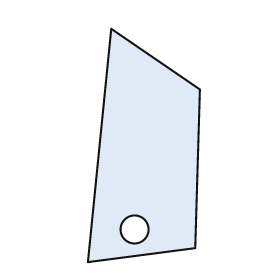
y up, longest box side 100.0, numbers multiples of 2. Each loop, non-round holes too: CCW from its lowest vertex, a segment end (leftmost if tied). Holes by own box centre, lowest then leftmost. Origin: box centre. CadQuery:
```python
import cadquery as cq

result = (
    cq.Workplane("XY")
    .moveTo(-24.0, -50.0)
    .lineTo(22.0, -44.0)
    .lineTo(24.0, 24.0)
    .lineTo(-14.0, 50.0)
    .close()
    .moveTo(-4.0, -36.0)
    .circle(6.0)
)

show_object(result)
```